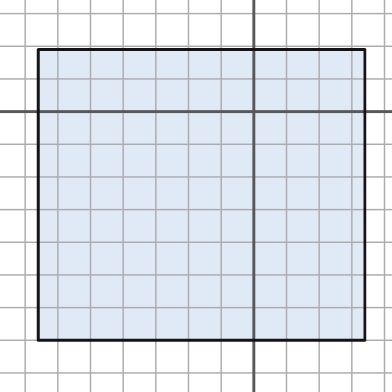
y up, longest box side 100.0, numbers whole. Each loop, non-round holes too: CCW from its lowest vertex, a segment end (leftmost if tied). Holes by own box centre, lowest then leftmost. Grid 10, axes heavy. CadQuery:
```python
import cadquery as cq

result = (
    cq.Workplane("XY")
    .moveTo(-66.0, -70.0)
    .lineTo(34.0, -70.0)
    .lineTo(34.0, 19.0)
    .lineTo(-66.0, 19.0)
    .close()
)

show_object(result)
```